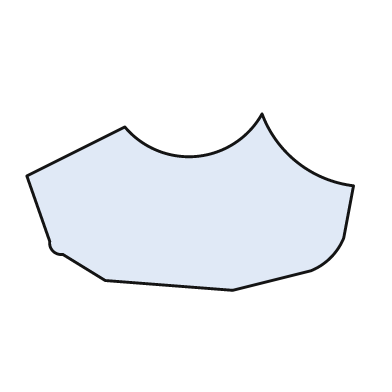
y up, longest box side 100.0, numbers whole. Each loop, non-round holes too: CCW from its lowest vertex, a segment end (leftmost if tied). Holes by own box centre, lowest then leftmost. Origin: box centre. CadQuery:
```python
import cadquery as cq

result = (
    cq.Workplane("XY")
    .moveTo(13.0, -27.0)
    .lineTo(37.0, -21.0)
    .threePointArc((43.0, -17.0), (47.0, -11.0))
    .lineTo(50.0, 5.0)
    .threePointArc((33.0, 12.0), (22.0, 27.0))
    .threePointArc((2.0, 14.0), (-20.0, 23.0))
    .lineTo(-50.0, 8.0)
    .lineTo(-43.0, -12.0)
    .threePointArc((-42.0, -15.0), (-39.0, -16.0))
    .lineTo(-26.0, -24.0)
    .close()
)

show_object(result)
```